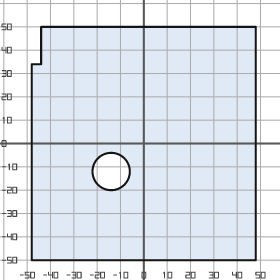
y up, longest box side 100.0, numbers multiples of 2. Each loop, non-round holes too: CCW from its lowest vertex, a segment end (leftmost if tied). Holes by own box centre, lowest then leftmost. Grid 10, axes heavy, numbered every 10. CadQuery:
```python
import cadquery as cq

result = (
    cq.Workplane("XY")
    .moveTo(-48.0, -50.0)
    .lineTo(48.0, -50.0)
    .lineTo(48.0, 50.0)
    .lineTo(-44.0, 50.0)
    .lineTo(-44.0, 34.0)
    .lineTo(-48.0, 34.0)
    .close()
    .moveTo(-14.0, -12.0)
    .circle(8.0)
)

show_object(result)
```